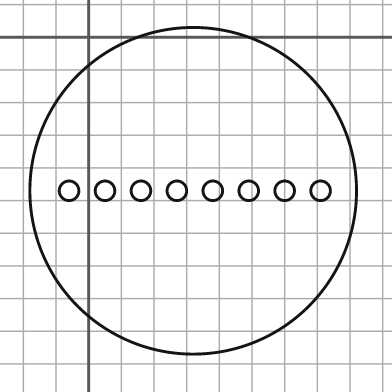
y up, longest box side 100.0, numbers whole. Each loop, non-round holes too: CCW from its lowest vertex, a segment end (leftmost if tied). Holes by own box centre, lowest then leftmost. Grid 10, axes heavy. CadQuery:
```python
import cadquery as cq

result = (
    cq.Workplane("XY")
    .moveTo(32.0, -47.0)
    .circle(50.0)
    .moveTo(-6.0, -47.0)
    .circle(3.0)
    .moveTo(5.0, -47.0)
    .circle(3.0)
    .moveTo(16.0, -47.0)
    .circle(3.0)
    .moveTo(27.0, -47.0)
    .circle(3.0)
    .moveTo(38.0, -47.0)
    .circle(3.0)
    .moveTo(49.0, -47.0)
    .circle(3.0)
    .moveTo(60.0, -47.0)
    .circle(3.0)
    .moveTo(71.0, -47.0)
    .circle(3.0)
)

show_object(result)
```